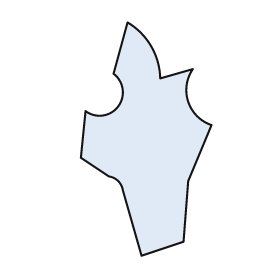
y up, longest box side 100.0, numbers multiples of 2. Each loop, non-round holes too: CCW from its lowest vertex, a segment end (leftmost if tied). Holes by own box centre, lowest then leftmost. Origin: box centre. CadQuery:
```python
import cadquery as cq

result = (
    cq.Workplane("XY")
    .moveTo(-2.0, -50.0)
    .lineTo(16.0, -44.0)
    .lineTo(18.0, -18.0)
    .lineTo(28.0, 6.0)
    .threePointArc((18.0, 16.0), (20.0, 30.0))
    .lineTo(6.0, 26.0)
    .threePointArc((2.0, 40.0), (-8.0, 50.0))
    .lineTo(-14.0, 28.0)
    .threePointArc((-12.0, 14.0), (-26.0, 12.0))
    .lineTo(-28.0, -8.0)
    .lineTo(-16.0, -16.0)
    .threePointArc((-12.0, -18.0), (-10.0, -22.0))
    .close()
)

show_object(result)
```